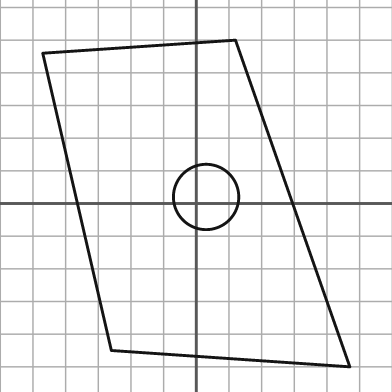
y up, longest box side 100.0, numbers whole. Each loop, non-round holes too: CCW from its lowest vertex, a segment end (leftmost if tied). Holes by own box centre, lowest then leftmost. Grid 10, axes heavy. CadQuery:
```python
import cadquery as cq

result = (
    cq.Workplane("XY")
    .moveTo(47.0, -50.0)
    .lineTo(12.0, 50.0)
    .lineTo(-47.0, 46.0)
    .lineTo(-26.0, -45.0)
    .close()
    .moveTo(3.0, 2.0)
    .circle(10.0)
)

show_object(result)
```